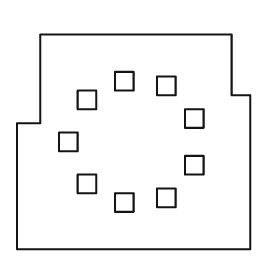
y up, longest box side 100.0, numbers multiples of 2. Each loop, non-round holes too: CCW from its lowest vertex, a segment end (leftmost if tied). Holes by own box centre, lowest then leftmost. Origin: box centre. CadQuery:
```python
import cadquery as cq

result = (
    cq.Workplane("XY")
    .moveTo(-50.0, -46.0)
    .lineTo(50.0, -46.0)
    .lineTo(50.0, 20.0)
    .lineTo(42.0, 20.0)
    .lineTo(42.0, 46.0)
    .lineTo(-40.0, 46.0)
    .lineTo(-40.0, 8.0)
    .lineTo(-50.0, 8.0)
    .close()
    .moveTo(-8.0, -30.0)
    .lineTo(0.0, -30.0)
    .lineTo(0.0, -22.0)
    .lineTo(-8.0, -22.0)
    .close()
    .moveTo(10.0, -28.0)
    .lineTo(18.0, -28.0)
    .lineTo(18.0, -20.0)
    .lineTo(10.0, -20.0)
    .close()
    .moveTo(-24.0, -22.0)
    .lineTo(-16.0, -22.0)
    .lineTo(-16.0, -14.0)
    .lineTo(-24.0, -14.0)
    .close()
    .moveTo(22.0, -14.0)
    .lineTo(30.0, -14.0)
    .lineTo(30.0, -6.0)
    .lineTo(22.0, -6.0)
    .close()
    .moveTo(-32.0, -4.0)
    .lineTo(-24.0, -4.0)
    .lineTo(-24.0, 4.0)
    .lineTo(-32.0, 4.0)
    .close()
    .moveTo(22.0, 6.0)
    .lineTo(30.0, 6.0)
    .lineTo(30.0, 14.0)
    .lineTo(22.0, 14.0)
    .close()
    .moveTo(-24.0, 14.0)
    .lineTo(-16.0, 14.0)
    .lineTo(-16.0, 22.0)
    .lineTo(-24.0, 22.0)
    .close()
    .moveTo(10.0, 20.0)
    .lineTo(18.0, 20.0)
    .lineTo(18.0, 28.0)
    .lineTo(10.0, 28.0)
    .close()
    .moveTo(-8.0, 22.0)
    .lineTo(0.0, 22.0)
    .lineTo(0.0, 30.0)
    .lineTo(-8.0, 30.0)
    .close()
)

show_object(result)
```